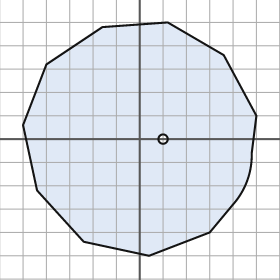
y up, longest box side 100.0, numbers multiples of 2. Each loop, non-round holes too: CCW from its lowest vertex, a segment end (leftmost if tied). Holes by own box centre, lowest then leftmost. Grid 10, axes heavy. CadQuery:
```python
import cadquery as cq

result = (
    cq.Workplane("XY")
    .moveTo(4.0, -50.0)
    .lineTo(30.0, -40.0)
    .lineTo(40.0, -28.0)
    .threePointArc((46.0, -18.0), (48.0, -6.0))
    .lineTo(50.0, 10.0)
    .lineTo(36.0, 36.0)
    .lineTo(12.0, 50.0)
    .lineTo(-16.0, 48.0)
    .lineTo(-40.0, 32.0)
    .lineTo(-50.0, 6.0)
    .lineTo(-44.0, -22.0)
    .lineTo(-24.0, -44.0)
    .close()
    .moveTo(10.0, 0.0)
    .circle(2.0)
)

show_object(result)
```